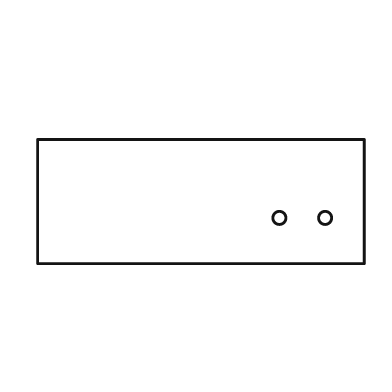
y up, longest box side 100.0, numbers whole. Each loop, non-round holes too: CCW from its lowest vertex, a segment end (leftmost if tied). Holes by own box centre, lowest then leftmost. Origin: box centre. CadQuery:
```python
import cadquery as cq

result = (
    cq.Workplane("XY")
    .moveTo(-50.0, -19.0)
    .lineTo(50.0, -19.0)
    .lineTo(50.0, 19.0)
    .lineTo(-50.0, 19.0)
    .close()
    .moveTo(24.0, -5.0)
    .circle(2.0)
    .moveTo(38.0, -5.0)
    .circle(2.0)
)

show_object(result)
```